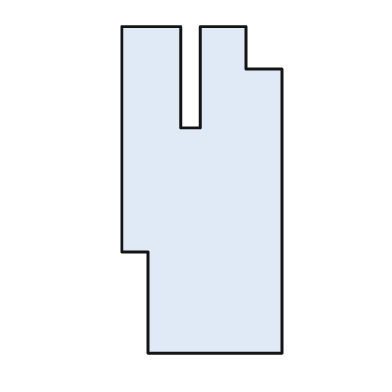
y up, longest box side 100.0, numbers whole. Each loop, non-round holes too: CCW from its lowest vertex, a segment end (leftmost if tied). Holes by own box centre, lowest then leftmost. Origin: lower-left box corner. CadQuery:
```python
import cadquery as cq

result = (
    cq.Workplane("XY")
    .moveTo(8.0, 0.0)
    .lineTo(49.0, 0.0)
    .lineTo(49.0, 87.0)
    .lineTo(38.0, 87.0)
    .lineTo(38.0, 100.0)
    .lineTo(24.0, 100.0)
    .lineTo(24.0, 69.0)
    .lineTo(18.0, 69.0)
    .lineTo(18.0, 100.0)
    .lineTo(0.0, 100.0)
    .lineTo(0.0, 31.0)
    .lineTo(8.0, 31.0)
    .close()
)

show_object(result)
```